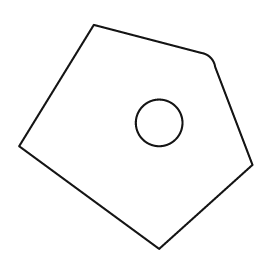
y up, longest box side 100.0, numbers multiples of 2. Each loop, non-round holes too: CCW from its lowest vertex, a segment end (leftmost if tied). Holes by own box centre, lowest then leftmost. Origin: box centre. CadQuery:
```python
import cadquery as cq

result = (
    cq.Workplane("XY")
    .moveTo(10.0, -48.0)
    .lineTo(50.0, -12.0)
    .lineTo(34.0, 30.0)
    .threePointArc((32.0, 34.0), (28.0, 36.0))
    .lineTo(-18.0, 48.0)
    .lineTo(-50.0, -4.0)
    .close()
    .moveTo(10.0, 6.0)
    .circle(10.0)
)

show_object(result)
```